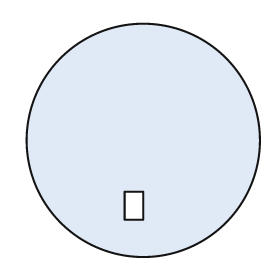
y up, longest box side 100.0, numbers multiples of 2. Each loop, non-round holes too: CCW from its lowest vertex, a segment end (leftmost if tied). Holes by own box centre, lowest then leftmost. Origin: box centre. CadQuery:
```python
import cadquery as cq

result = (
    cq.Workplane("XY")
    .moveTo(0.0, 0.0)
    .circle(50.0)
    .moveTo(-8.0, -34.0)
    .lineTo(0.0, -34.0)
    .lineTo(0.0, -22.0)
    .lineTo(-8.0, -22.0)
    .close()
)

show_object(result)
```